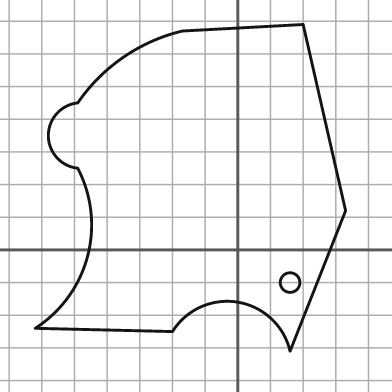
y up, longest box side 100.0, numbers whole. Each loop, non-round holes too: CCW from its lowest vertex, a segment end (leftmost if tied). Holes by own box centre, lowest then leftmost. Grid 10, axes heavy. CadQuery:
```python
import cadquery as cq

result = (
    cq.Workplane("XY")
    .moveTo(16.0, -31.0)
    .lineTo(33.0, 12.0)
    .lineTo(20.0, 69.0)
    .lineTo(-17.0, 67.0)
    .threePointArc((-35.0, 59.0), (-49.0, 45.0))
    .threePointArc((-58.0, 35.0), (-49.0, 25.0))
    .threePointArc((-46.0, -2.0), (-62.0, -24.0))
    .lineTo(-20.0, -25.0)
    .threePointArc((0.0, -16.0), (16.0, -31.0))
    .close()
    .moveTo(16.0, -10.0)
    .circle(3.0)
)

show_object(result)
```